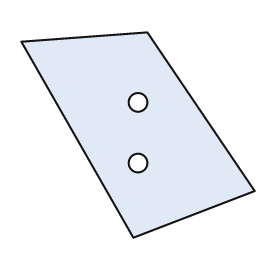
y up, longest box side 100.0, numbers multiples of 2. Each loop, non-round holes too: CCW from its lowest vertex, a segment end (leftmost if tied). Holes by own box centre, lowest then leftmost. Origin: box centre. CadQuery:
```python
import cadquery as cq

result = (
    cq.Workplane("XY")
    .moveTo(-2.0, -44.0)
    .lineTo(50.0, -24.0)
    .lineTo(4.0, 44.0)
    .lineTo(-50.0, 40.0)
    .close()
    .moveTo(0.0, -12.0)
    .circle(4.0)
    .moveTo(0.0, 14.0)
    .circle(4.0)
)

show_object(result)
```